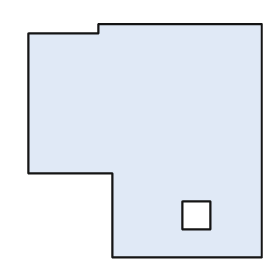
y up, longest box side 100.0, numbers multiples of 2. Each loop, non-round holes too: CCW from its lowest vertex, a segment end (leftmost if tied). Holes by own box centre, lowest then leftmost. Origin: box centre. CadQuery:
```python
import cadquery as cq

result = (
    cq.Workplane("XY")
    .moveTo(-14.0, -50.0)
    .lineTo(50.0, -50.0)
    .lineTo(50.0, 50.0)
    .lineTo(-20.0, 50.0)
    .lineTo(-20.0, 46.0)
    .lineTo(-50.0, 46.0)
    .lineTo(-50.0, -14.0)
    .lineTo(-14.0, -14.0)
    .close()
    .moveTo(16.0, -38.0)
    .lineTo(28.0, -38.0)
    .lineTo(28.0, -26.0)
    .lineTo(16.0, -26.0)
    .close()
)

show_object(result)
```